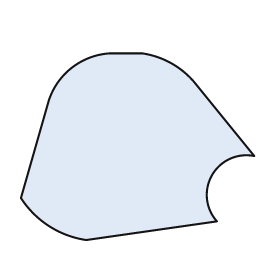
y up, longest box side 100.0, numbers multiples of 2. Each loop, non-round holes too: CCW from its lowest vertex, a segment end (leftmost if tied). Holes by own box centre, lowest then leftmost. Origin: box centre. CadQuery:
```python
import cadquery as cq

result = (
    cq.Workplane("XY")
    .moveTo(-22.0, -40.0)
    .lineTo(34.0, -32.0)
    .threePointArc((32.0, -12.0), (50.0, -4.0))
    .lineTo(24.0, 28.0)
    .threePointArc((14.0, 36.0), (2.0, 40.0))
    .lineTo(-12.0, 40.0)
    .threePointArc((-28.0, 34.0), (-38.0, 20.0))
    .lineTo(-50.0, -22.0)
    .threePointArc((-38.0, -34.0), (-22.0, -40.0))
    .close()
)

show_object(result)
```